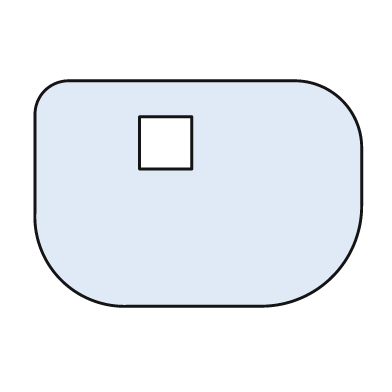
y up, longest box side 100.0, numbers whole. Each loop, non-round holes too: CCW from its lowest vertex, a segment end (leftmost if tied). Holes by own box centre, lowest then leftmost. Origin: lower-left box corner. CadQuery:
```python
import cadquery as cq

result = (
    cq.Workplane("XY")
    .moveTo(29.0, 0.0)
    .lineTo(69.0, 0.0)
    .threePointArc((91.0, 9.0), (100.0, 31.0))
    .lineTo(100.0, 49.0)
    .threePointArc((94.0, 63.0), (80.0, 69.0))
    .lineTo(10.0, 69.0)
    .threePointArc((3.0, 66.0), (0.0, 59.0))
    .lineTo(0.0, 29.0)
    .threePointArc((8.0, 8.0), (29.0, 0.0))
    .close()
    .moveTo(32.0, 42.0)
    .lineTo(48.0, 42.0)
    .lineTo(48.0, 58.0)
    .lineTo(32.0, 58.0)
    .close()
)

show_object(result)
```